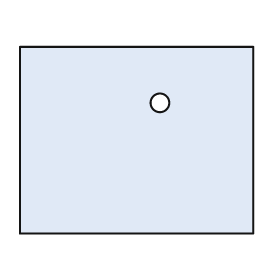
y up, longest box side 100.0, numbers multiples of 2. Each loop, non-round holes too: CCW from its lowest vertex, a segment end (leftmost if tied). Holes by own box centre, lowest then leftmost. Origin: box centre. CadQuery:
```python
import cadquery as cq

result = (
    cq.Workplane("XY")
    .moveTo(-50.0, -40.0)
    .lineTo(50.0, -40.0)
    .lineTo(50.0, 40.0)
    .lineTo(-50.0, 40.0)
    .close()
    .moveTo(10.0, 16.0)
    .circle(4.0)
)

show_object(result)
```